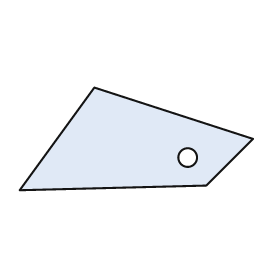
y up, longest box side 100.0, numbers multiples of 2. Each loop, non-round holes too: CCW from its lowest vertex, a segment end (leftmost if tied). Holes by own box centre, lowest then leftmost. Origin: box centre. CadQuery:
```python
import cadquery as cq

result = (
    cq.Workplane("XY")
    .moveTo(-50.0, -22.0)
    .lineTo(30.0, -20.0)
    .lineTo(50.0, 0.0)
    .lineTo(-18.0, 22.0)
    .close()
    .moveTo(22.0, -8.0)
    .circle(4.0)
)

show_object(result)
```